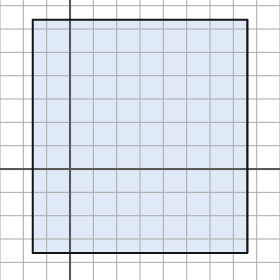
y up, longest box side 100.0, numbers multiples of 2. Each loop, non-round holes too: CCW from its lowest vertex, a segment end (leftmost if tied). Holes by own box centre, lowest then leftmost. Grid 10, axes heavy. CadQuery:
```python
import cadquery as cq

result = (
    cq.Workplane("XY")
    .moveTo(-16.0, -36.0)
    .lineTo(76.0, -36.0)
    .lineTo(76.0, 64.0)
    .lineTo(-16.0, 64.0)
    .close()
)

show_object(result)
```